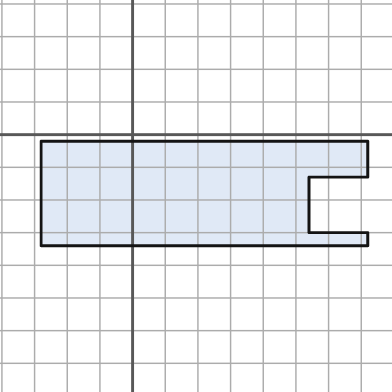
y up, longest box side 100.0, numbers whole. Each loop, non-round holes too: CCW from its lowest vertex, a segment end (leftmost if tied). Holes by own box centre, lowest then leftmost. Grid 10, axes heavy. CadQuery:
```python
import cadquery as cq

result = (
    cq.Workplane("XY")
    .moveTo(-28.0, -34.0)
    .lineTo(72.0, -34.0)
    .lineTo(72.0, -30.0)
    .lineTo(54.0, -30.0)
    .lineTo(54.0, -13.0)
    .lineTo(72.0, -13.0)
    .lineTo(72.0, -2.0)
    .lineTo(-28.0, -2.0)
    .close()
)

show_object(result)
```